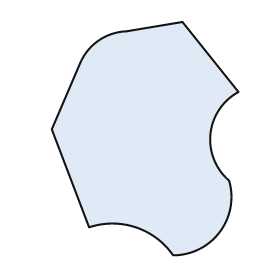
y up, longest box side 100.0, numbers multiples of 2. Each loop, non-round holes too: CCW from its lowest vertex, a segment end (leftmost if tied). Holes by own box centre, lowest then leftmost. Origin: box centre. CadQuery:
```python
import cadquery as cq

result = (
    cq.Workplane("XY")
    .moveTo(12.0, -50.0)
    .threePointArc((32.0, -40.0), (36.0, -18.0))
    .threePointArc((28.0, 2.0), (40.0, 20.0))
    .lineTo(16.0, 50.0)
    .lineTo(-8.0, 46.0)
    .threePointArc((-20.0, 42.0), (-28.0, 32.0))
    .lineTo(-40.0, 4.0)
    .lineTo(-24.0, -38.0)
    .threePointArc((-4.0, -38.0), (12.0, -50.0))
    .close()
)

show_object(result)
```